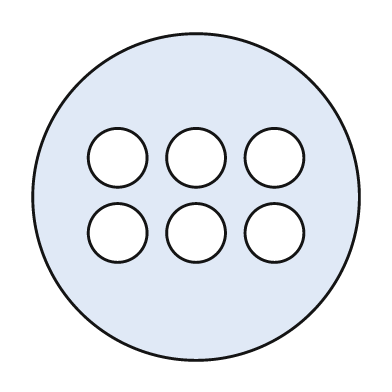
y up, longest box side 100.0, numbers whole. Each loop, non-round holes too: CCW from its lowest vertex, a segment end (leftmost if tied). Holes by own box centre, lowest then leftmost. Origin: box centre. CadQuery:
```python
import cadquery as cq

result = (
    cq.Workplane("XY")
    .moveTo(0.0, 0.0)
    .circle(50.0)
    .moveTo(-24.0, -11.0)
    .circle(9.0)
    .moveTo(0.0, -11.0)
    .circle(9.0)
    .moveTo(24.0, -11.0)
    .circle(9.0)
    .moveTo(-24.0, 12.0)
    .circle(9.0)
    .moveTo(0.0, 12.0)
    .circle(9.0)
    .moveTo(24.0, 12.0)
    .circle(9.0)
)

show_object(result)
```